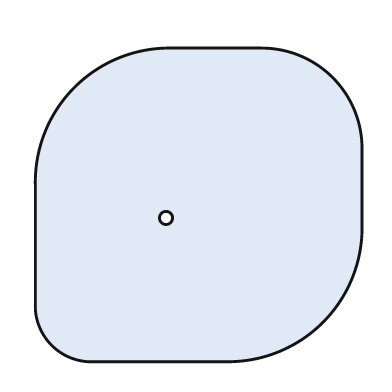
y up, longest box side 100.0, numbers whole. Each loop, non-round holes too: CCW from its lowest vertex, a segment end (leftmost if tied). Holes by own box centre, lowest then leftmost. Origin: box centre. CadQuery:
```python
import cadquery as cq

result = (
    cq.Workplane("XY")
    .moveTo(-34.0, -48.0)
    .lineTo(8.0, -48.0)
    .threePointArc((38.0, -36.0), (50.0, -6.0))
    .lineTo(50.0, 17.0)
    .threePointArc((41.0, 39.0), (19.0, 48.0))
    .lineTo(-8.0, 48.0)
    .threePointArc((-38.0, 36.0), (-50.0, 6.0))
    .lineTo(-50.0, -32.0)
    .threePointArc((-45.0, -43.0), (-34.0, -48.0))
    .close()
    .moveTo(-10.0, -4.0)
    .circle(2.0)
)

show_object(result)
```